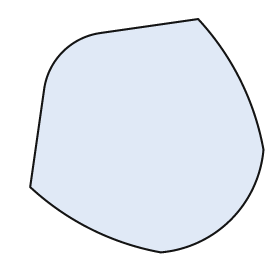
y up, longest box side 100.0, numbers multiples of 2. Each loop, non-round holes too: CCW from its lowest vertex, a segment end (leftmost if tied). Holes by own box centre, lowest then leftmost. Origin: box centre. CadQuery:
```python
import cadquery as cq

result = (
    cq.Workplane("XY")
    .moveTo(6.0, -50.0)
    .threePointArc((36.0, -36.0), (50.0, -6.0))
    .threePointArc((40.0, 24.0), (22.0, 50.0))
    .lineTo(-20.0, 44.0)
    .threePointArc((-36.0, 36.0), (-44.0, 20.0))
    .lineTo(-50.0, -22.0)
    .threePointArc((-24.0, -40.0), (6.0, -50.0))
    .close()
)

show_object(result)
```